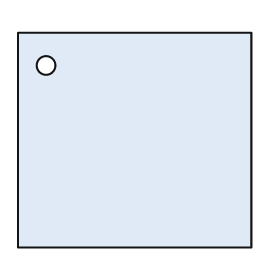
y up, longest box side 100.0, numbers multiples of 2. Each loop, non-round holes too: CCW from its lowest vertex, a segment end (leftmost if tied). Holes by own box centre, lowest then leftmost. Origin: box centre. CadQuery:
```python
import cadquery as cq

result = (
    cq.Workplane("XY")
    .moveTo(-50.0, -46.0)
    .lineTo(50.0, -46.0)
    .lineTo(50.0, 46.0)
    .lineTo(-50.0, 46.0)
    .close()
    .moveTo(-38.0, 32.0)
    .circle(4.0)
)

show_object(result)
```